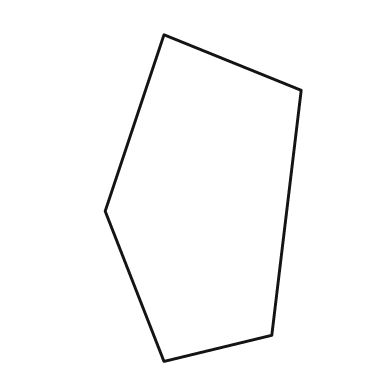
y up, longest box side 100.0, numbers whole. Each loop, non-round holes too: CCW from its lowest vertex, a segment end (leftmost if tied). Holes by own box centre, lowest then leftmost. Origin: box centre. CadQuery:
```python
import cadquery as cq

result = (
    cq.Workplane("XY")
    .moveTo(-12.0, -50.0)
    .lineTo(21.0, -42.0)
    .lineTo(30.0, 33.0)
    .lineTo(-12.0, 50.0)
    .lineTo(-30.0, -4.0)
    .close()
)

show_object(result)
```